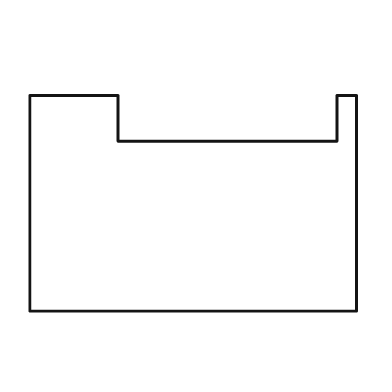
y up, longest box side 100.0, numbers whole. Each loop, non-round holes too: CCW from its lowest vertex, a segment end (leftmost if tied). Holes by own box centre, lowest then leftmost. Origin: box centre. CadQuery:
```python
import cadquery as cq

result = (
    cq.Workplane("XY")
    .moveTo(-50.0, -33.0)
    .lineTo(50.0, -33.0)
    .lineTo(50.0, 33.0)
    .lineTo(44.0, 33.0)
    .lineTo(44.0, 19.0)
    .lineTo(-23.0, 19.0)
    .lineTo(-23.0, 33.0)
    .lineTo(-50.0, 33.0)
    .close()
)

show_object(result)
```